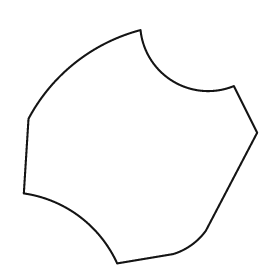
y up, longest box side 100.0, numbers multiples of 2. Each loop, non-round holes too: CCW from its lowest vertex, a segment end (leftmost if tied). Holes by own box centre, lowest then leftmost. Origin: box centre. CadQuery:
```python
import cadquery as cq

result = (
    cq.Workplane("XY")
    .moveTo(-10.0, -50.0)
    .lineTo(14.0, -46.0)
    .threePointArc((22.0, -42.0), (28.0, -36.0))
    .lineTo(50.0, 6.0)
    .lineTo(40.0, 26.0)
    .threePointArc((14.0, 28.0), (0.0, 50.0))
    .threePointArc((-28.0, 36.0), (-48.0, 12.0))
    .lineTo(-50.0, -20.0)
    .threePointArc((-26.0, -30.0), (-10.0, -50.0))
    .close()
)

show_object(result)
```